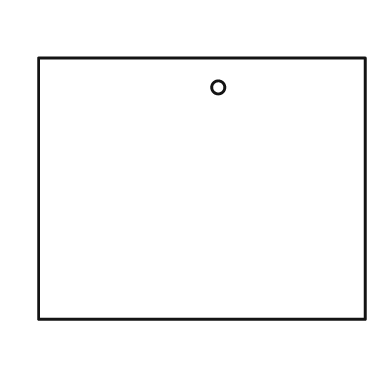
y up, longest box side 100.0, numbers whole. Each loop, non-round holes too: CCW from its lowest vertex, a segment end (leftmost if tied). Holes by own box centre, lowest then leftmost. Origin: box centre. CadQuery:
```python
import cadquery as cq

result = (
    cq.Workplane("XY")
    .moveTo(-50.0, -40.0)
    .lineTo(50.0, -40.0)
    .lineTo(50.0, 40.0)
    .lineTo(-50.0, 40.0)
    .close()
    .moveTo(5.0, 31.0)
    .circle(2.0)
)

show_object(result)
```